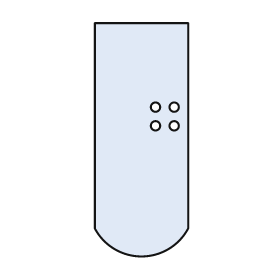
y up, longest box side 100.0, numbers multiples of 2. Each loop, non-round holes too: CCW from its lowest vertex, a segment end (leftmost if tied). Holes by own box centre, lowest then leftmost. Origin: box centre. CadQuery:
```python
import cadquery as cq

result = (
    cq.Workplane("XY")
    .moveTo(-20.0, -38.0)
    .threePointArc((0.0, -50.0), (20.0, -38.0))
    .lineTo(20.0, 50.0)
    .lineTo(-20.0, 50.0)
    .close()
    .moveTo(6.0, 6.0)
    .circle(2.0)
    .moveTo(14.0, 6.0)
    .circle(2.0)
    .moveTo(6.0, 14.0)
    .circle(2.0)
    .moveTo(14.0, 14.0)
    .circle(2.0)
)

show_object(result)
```